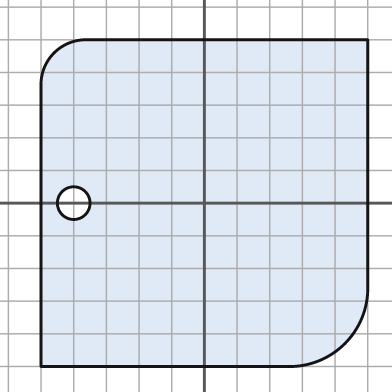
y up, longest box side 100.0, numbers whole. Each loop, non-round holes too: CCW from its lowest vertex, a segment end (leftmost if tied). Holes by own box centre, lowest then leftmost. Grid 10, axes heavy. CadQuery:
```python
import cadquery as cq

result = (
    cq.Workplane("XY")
    .moveTo(-50.0, -50.0)
    .lineTo(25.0, -50.0)
    .threePointArc((43.0, -43.0), (50.0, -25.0))
    .lineTo(50.0, 50.0)
    .lineTo(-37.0, 50.0)
    .threePointArc((-46.0, 46.0), (-50.0, 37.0))
    .close()
    .moveTo(-40.0, 0.0)
    .circle(5.0)
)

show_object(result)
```